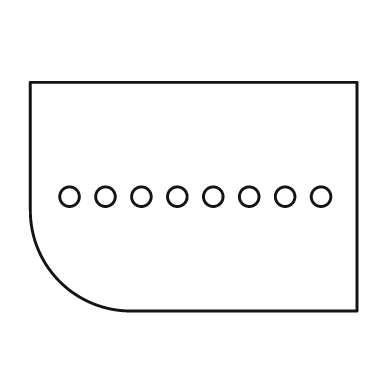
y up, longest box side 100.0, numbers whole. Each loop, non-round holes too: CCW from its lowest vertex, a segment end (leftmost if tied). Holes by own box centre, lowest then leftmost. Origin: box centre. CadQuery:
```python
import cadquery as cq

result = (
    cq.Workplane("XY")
    .moveTo(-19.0, -35.0)
    .lineTo(50.0, -35.0)
    .lineTo(50.0, 35.0)
    .lineTo(-50.0, 35.0)
    .lineTo(-50.0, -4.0)
    .threePointArc((-41.0, -26.0), (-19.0, -35.0))
    .close()
    .moveTo(-38.0, 0.0)
    .circle(3.0)
    .moveTo(-27.0, 0.0)
    .circle(3.0)
    .moveTo(-16.0, 0.0)
    .circle(3.0)
    .moveTo(-5.0, 0.0)
    .circle(3.0)
    .moveTo(6.0, 0.0)
    .circle(3.0)
    .moveTo(17.0, 0.0)
    .circle(3.0)
    .moveTo(28.0, 0.0)
    .circle(3.0)
    .moveTo(39.0, 0.0)
    .circle(3.0)
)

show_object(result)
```